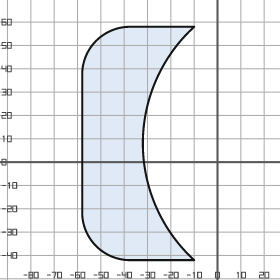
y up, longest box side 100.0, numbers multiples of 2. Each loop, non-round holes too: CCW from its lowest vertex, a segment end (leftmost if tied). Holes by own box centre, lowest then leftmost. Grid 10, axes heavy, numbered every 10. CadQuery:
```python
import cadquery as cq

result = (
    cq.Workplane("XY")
    .moveTo(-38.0, -42.0)
    .lineTo(-10.0, -42.0)
    .threePointArc((-32.0, 8.0), (-10.0, 58.0))
    .lineTo(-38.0, 58.0)
    .threePointArc((-52.0, 52.0), (-58.0, 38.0))
    .lineTo(-58.0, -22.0)
    .threePointArc((-52.0, -36.0), (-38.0, -42.0))
    .close()
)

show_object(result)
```